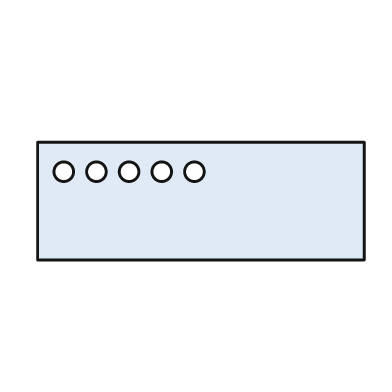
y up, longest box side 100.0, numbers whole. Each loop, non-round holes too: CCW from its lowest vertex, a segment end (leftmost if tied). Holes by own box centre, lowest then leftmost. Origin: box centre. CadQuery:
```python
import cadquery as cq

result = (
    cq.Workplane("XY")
    .moveTo(-50.0, -18.0)
    .lineTo(50.0, -18.0)
    .lineTo(50.0, 18.0)
    .lineTo(-50.0, 18.0)
    .close()
    .moveTo(-42.0, 9.0)
    .circle(3.0)
    .moveTo(-32.0, 9.0)
    .circle(3.0)
    .moveTo(-22.0, 9.0)
    .circle(3.0)
    .moveTo(-12.0, 9.0)
    .circle(3.0)
    .moveTo(-2.0, 9.0)
    .circle(3.0)
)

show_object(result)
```